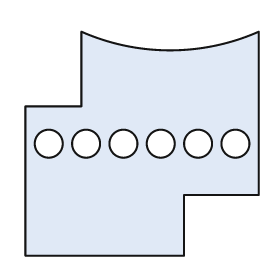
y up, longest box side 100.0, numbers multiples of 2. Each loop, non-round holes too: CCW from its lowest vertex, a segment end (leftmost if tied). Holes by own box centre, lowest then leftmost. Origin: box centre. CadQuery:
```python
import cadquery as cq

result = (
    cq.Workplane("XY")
    .moveTo(-50.0, -48.0)
    .lineTo(18.0, -48.0)
    .lineTo(18.0, -22.0)
    .lineTo(50.0, -22.0)
    .lineTo(50.0, 48.0)
    .threePointArc((12.0, 40.0), (-26.0, 48.0))
    .lineTo(-26.0, 16.0)
    .lineTo(-50.0, 16.0)
    .close()
    .moveTo(-40.0, 0.0)
    .circle(6.0)
    .moveTo(-24.0, 0.0)
    .circle(6.0)
    .moveTo(-8.0, 0.0)
    .circle(6.0)
    .moveTo(8.0, 0.0)
    .circle(6.0)
    .moveTo(24.0, 0.0)
    .circle(6.0)
    .moveTo(40.0, 0.0)
    .circle(6.0)
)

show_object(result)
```